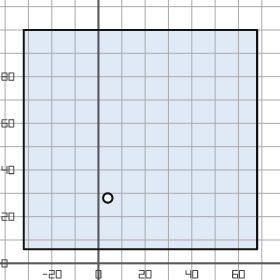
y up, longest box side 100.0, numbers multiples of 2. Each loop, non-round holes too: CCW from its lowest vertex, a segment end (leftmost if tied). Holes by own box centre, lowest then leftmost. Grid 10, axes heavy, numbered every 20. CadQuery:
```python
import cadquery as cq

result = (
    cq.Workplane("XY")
    .moveTo(-32.0, 6.0)
    .lineTo(68.0, 6.0)
    .lineTo(68.0, 100.0)
    .lineTo(-32.0, 100.0)
    .close()
    .moveTo(4.0, 28.0)
    .circle(2.0)
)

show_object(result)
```